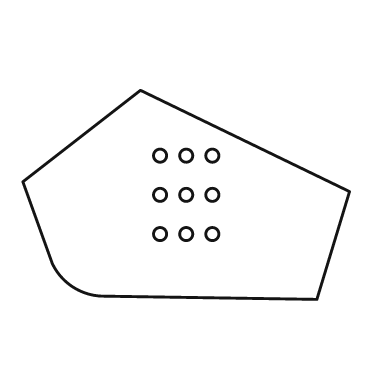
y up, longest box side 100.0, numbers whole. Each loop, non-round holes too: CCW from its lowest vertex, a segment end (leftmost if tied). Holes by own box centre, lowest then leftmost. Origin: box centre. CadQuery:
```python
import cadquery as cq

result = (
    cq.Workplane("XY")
    .moveTo(40.0, -32.0)
    .lineTo(50.0, 1.0)
    .lineTo(-14.0, 32.0)
    .lineTo(-50.0, 4.0)
    .lineTo(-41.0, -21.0)
    .threePointArc((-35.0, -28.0), (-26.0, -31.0))
    .close()
    .moveTo(-8.0, -12.0)
    .circle(2.0)
    .moveTo(0.0, -12.0)
    .circle(2.0)
    .moveTo(8.0, -12.0)
    .circle(2.0)
    .moveTo(-8.0, 0.0)
    .circle(2.0)
    .moveTo(0.0, 0.0)
    .circle(2.0)
    .moveTo(8.0, 0.0)
    .circle(2.0)
    .moveTo(-8.0, 12.0)
    .circle(2.0)
    .moveTo(0.0, 12.0)
    .circle(2.0)
    .moveTo(8.0, 12.0)
    .circle(2.0)
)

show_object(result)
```